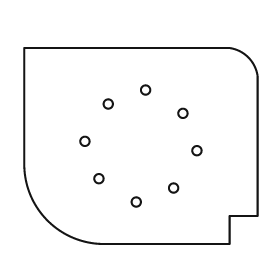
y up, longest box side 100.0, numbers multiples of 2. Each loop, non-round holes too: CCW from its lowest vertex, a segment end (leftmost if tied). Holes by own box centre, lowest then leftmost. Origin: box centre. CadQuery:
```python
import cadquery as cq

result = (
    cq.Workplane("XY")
    .moveTo(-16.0, -42.0)
    .lineTo(38.0, -42.0)
    .lineTo(38.0, -30.0)
    .lineTo(50.0, -30.0)
    .lineTo(50.0, 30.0)
    .threePointArc((46.0, 38.0), (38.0, 42.0))
    .lineTo(-50.0, 42.0)
    .lineTo(-50.0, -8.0)
    .threePointArc((-40.0, -32.0), (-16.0, -42.0))
    .close()
    .moveTo(-2.0, -24.0)
    .circle(2.0)
    .moveTo(14.0, -18.0)
    .circle(2.0)
    .moveTo(-18.0, -14.0)
    .circle(2.0)
    .moveTo(24.0, -2.0)
    .circle(2.0)
    .moveTo(-24.0, 2.0)
    .circle(2.0)
    .moveTo(18.0, 14.0)
    .circle(2.0)
    .moveTo(-14.0, 18.0)
    .circle(2.0)
    .moveTo(2.0, 24.0)
    .circle(2.0)
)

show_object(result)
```